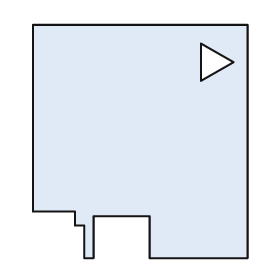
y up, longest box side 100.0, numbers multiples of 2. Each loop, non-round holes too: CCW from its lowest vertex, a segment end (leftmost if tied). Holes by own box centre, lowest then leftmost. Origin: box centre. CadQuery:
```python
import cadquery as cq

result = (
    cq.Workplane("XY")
    .moveTo(-24.0, -50.0)
    .lineTo(-20.0, -50.0)
    .lineTo(-20.0, -32.0)
    .lineTo(4.0, -32.0)
    .lineTo(4.0, -50.0)
    .lineTo(46.0, -50.0)
    .lineTo(46.0, 50.0)
    .lineTo(-46.0, 50.0)
    .lineTo(-46.0, -30.0)
    .lineTo(-28.0, -30.0)
    .lineTo(-28.0, -36.0)
    .lineTo(-24.0, -36.0)
    .close()
    .moveTo(26.0, 26.0)
    .lineTo(40.0, 34.0)
    .lineTo(26.0, 42.0)
    .close()
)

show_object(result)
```